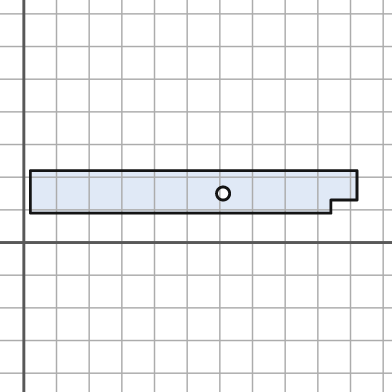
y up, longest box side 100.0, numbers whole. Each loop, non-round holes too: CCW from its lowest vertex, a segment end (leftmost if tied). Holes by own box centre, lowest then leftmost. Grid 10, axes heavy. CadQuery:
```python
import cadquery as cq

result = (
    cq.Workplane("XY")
    .moveTo(2.0, 9.0)
    .lineTo(94.0, 9.0)
    .lineTo(94.0, 13.0)
    .lineTo(102.0, 13.0)
    .lineTo(102.0, 22.0)
    .lineTo(2.0, 22.0)
    .close()
    .moveTo(61.0, 15.0)
    .circle(2.0)
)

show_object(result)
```